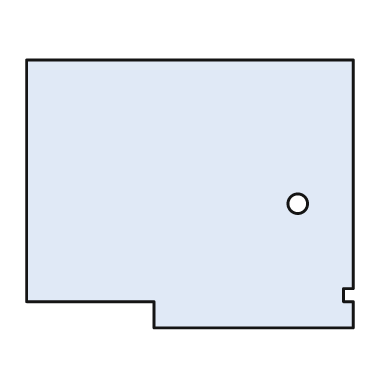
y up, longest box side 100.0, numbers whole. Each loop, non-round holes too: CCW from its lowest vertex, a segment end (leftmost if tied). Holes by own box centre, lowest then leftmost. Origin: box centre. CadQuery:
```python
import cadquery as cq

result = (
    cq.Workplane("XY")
    .moveTo(-11.0, -41.0)
    .lineTo(50.0, -41.0)
    .lineTo(50.0, -33.0)
    .lineTo(47.0, -33.0)
    .lineTo(47.0, -29.0)
    .lineTo(50.0, -29.0)
    .lineTo(50.0, 41.0)
    .lineTo(-50.0, 41.0)
    .lineTo(-50.0, -33.0)
    .lineTo(-11.0, -33.0)
    .close()
    .moveTo(33.0, -3.0)
    .circle(3.0)
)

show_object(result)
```